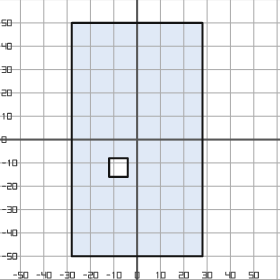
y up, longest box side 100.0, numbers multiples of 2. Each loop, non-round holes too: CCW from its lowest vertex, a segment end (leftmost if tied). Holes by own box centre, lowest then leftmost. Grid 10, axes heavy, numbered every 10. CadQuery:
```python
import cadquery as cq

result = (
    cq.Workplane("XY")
    .moveTo(-28.0, -50.0)
    .lineTo(28.0, -50.0)
    .lineTo(28.0, 50.0)
    .lineTo(-28.0, 50.0)
    .close()
    .moveTo(-12.0, -16.0)
    .lineTo(-4.0, -16.0)
    .lineTo(-4.0, -8.0)
    .lineTo(-12.0, -8.0)
    .close()
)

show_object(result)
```